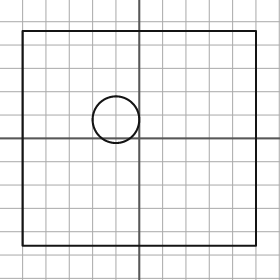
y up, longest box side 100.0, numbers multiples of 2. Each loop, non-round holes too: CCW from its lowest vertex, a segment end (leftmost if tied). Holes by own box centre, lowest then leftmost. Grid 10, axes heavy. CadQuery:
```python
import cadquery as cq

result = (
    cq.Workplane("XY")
    .moveTo(-50.0, -46.0)
    .lineTo(50.0, -46.0)
    .lineTo(50.0, 46.0)
    .lineTo(-50.0, 46.0)
    .close()
    .moveTo(-10.0, 8.0)
    .circle(10.0)
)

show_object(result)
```